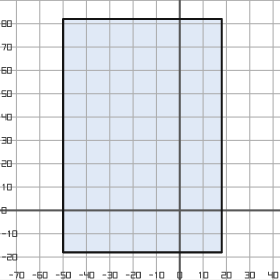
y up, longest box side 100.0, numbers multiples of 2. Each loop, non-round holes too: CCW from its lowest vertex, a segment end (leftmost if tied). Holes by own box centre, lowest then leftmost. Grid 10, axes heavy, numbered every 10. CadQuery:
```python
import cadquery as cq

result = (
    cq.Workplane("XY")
    .moveTo(-50.0, -18.0)
    .lineTo(18.0, -18.0)
    .lineTo(18.0, 82.0)
    .lineTo(-50.0, 82.0)
    .close()
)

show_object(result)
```